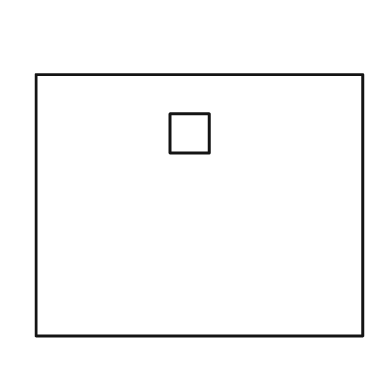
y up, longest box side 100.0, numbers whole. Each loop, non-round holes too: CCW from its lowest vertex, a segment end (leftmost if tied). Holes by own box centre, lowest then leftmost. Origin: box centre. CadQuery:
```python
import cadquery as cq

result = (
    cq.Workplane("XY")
    .moveTo(-50.0, -40.0)
    .lineTo(50.0, -40.0)
    .lineTo(50.0, 40.0)
    .lineTo(-50.0, 40.0)
    .close()
    .moveTo(-9.0, 16.0)
    .lineTo(3.0, 16.0)
    .lineTo(3.0, 28.0)
    .lineTo(-9.0, 28.0)
    .close()
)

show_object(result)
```